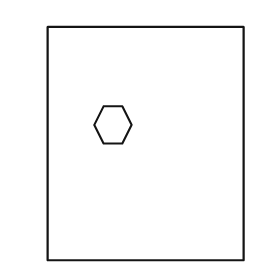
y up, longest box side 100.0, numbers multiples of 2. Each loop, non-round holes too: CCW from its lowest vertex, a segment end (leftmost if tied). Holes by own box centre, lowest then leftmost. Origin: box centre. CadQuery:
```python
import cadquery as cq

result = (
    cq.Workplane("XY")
    .moveTo(-42.0, -50.0)
    .lineTo(42.0, -50.0)
    .lineTo(42.0, 50.0)
    .lineTo(-42.0, 50.0)
    .close()
    .moveTo(-18.0, 0.0)
    .lineTo(-10.0, 0.0)
    .lineTo(-6.0, 8.0)
    .lineTo(-10.0, 16.0)
    .lineTo(-18.0, 16.0)
    .lineTo(-22.0, 8.0)
    .close()
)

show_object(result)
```